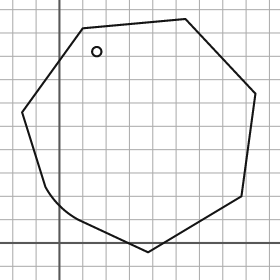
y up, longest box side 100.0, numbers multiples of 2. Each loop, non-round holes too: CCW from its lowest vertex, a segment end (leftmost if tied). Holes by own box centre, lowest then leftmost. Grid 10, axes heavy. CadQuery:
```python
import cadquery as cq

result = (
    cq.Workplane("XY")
    .moveTo(38.0, -4.0)
    .lineTo(78.0, 20.0)
    .lineTo(84.0, 64.0)
    .lineTo(54.0, 96.0)
    .lineTo(10.0, 92.0)
    .lineTo(-16.0, 56.0)
    .lineTo(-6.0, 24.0)
    .threePointArc((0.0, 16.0), (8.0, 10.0))
    .close()
    .moveTo(16.0, 82.0)
    .circle(2.0)
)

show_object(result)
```